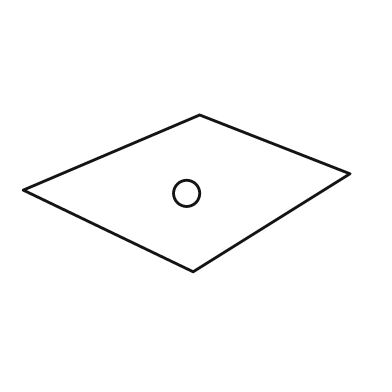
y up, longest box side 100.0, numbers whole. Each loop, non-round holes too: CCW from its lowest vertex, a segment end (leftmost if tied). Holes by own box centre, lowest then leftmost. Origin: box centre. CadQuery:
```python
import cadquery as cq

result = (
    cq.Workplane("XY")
    .moveTo(2.0, -24.0)
    .lineTo(50.0, 6.0)
    .lineTo(4.0, 24.0)
    .lineTo(-50.0, 1.0)
    .close()
    .moveTo(0.0, 0.0)
    .circle(4.0)
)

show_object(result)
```